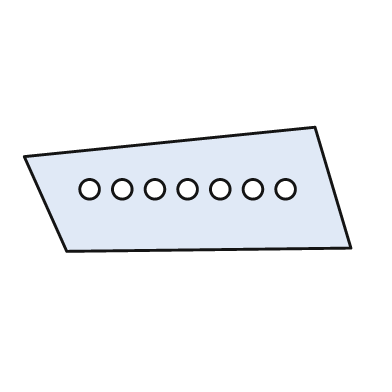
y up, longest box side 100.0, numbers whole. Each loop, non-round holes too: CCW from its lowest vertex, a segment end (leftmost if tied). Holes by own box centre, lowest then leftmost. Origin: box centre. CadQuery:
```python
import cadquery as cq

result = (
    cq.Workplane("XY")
    .moveTo(-37.0, -19.0)
    .lineTo(50.0, -18.0)
    .lineTo(39.0, 19.0)
    .lineTo(-50.0, 10.0)
    .close()
    .moveTo(-30.0, 0.0)
    .circle(3.0)
    .moveTo(-20.0, 0.0)
    .circle(3.0)
    .moveTo(-10.0, 0.0)
    .circle(3.0)
    .moveTo(0.0, 0.0)
    .circle(3.0)
    .moveTo(10.0, 0.0)
    .circle(3.0)
    .moveTo(20.0, 0.0)
    .circle(3.0)
    .moveTo(30.0, 0.0)
    .circle(3.0)
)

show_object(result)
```